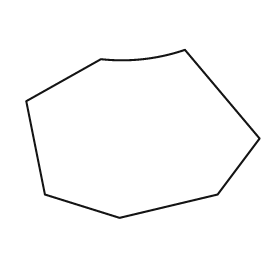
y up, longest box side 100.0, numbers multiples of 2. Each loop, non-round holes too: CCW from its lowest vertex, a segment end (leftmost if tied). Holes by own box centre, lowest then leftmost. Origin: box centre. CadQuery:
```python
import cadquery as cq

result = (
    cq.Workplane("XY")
    .moveTo(-10.0, -36.0)
    .lineTo(32.0, -26.0)
    .lineTo(50.0, -2.0)
    .lineTo(18.0, 36.0)
    .threePointArc((0.0, 32.0), (-18.0, 32.0))
    .lineTo(-50.0, 14.0)
    .lineTo(-42.0, -26.0)
    .close()
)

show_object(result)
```